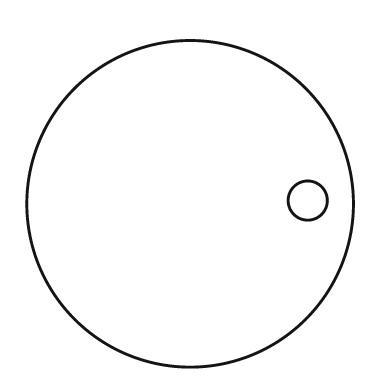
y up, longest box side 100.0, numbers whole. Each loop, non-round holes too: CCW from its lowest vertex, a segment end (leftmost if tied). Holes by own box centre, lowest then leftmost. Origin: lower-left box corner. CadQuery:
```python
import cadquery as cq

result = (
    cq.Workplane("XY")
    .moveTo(50.0, 50.0)
    .circle(50.0)
    .moveTo(86.0, 51.0)
    .circle(6.0)
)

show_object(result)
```